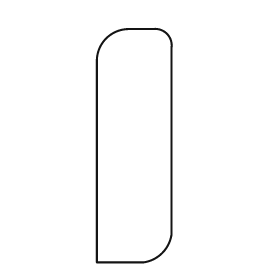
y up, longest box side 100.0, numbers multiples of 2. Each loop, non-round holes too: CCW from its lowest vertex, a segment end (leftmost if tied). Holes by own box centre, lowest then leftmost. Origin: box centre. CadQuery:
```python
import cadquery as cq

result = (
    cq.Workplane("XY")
    .moveTo(-16.0, -50.0)
    .lineTo(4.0, -50.0)
    .threePointArc((12.0, -46.0), (16.0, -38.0))
    .lineTo(16.0, 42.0)
    .threePointArc((14.0, 48.0), (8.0, 50.0))
    .lineTo(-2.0, 50.0)
    .threePointArc((-12.0, 46.0), (-16.0, 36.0))
    .close()
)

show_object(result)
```